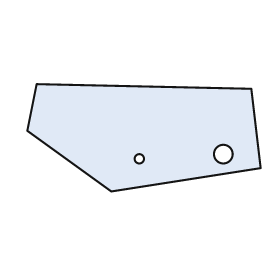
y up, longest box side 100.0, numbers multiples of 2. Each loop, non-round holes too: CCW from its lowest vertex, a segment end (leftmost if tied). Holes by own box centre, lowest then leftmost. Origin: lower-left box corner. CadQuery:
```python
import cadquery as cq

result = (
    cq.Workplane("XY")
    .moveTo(36.0, 0.0)
    .lineTo(100.0, 10.0)
    .lineTo(96.0, 44.0)
    .lineTo(4.0, 46.0)
    .lineTo(0.0, 26.0)
    .close()
    .moveTo(48.0, 14.0)
    .circle(2.0)
    .moveTo(84.0, 16.0)
    .circle(4.0)
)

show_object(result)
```